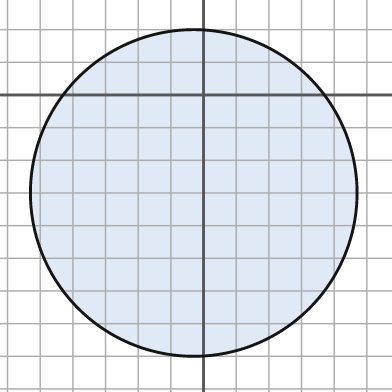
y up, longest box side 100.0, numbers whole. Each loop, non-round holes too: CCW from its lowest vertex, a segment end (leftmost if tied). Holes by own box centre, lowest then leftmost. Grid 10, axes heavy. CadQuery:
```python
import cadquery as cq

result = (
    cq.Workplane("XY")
    .moveTo(-3.0, -30.0)
    .circle(50.0)
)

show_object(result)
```